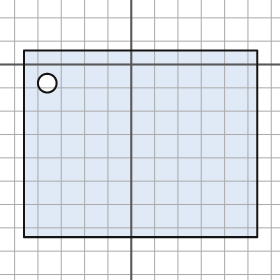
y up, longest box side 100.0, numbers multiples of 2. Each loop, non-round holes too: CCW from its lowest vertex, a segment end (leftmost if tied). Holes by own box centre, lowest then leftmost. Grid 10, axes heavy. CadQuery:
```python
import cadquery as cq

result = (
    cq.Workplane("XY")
    .moveTo(-46.0, -74.0)
    .lineTo(54.0, -74.0)
    .lineTo(54.0, 6.0)
    .lineTo(-46.0, 6.0)
    .close()
    .moveTo(-36.0, -8.0)
    .circle(4.0)
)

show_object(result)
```